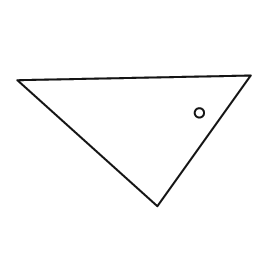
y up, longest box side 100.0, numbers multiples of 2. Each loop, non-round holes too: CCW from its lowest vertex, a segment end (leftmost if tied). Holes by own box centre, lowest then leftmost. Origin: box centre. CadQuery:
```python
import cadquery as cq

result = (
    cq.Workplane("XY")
    .moveTo(10.0, -28.0)
    .lineTo(50.0, 28.0)
    .lineTo(-50.0, 26.0)
    .close()
    .moveTo(28.0, 12.0)
    .circle(2.0)
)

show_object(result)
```